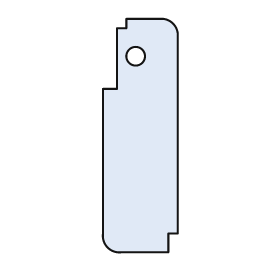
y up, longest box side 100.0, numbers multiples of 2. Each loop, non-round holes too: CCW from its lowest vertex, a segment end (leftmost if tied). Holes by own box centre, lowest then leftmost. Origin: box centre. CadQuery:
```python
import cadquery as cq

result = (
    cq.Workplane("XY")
    .moveTo(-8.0, -50.0)
    .lineTo(12.0, -50.0)
    .lineTo(12.0, -42.0)
    .lineTo(16.0, -42.0)
    .lineTo(16.0, 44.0)
    .threePointArc((14.0, 48.0), (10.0, 50.0))
    .lineTo(-6.0, 50.0)
    .lineTo(-6.0, 46.0)
    .lineTo(-10.0, 46.0)
    .lineTo(-10.0, 20.0)
    .lineTo(-16.0, 20.0)
    .lineTo(-16.0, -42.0)
    .threePointArc((-14.0, -48.0), (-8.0, -50.0))
    .close()
    .moveTo(-2.0, 34.0)
    .circle(4.0)
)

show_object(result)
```